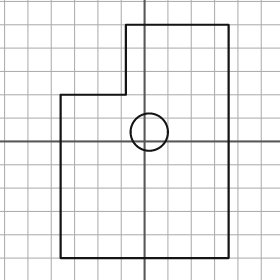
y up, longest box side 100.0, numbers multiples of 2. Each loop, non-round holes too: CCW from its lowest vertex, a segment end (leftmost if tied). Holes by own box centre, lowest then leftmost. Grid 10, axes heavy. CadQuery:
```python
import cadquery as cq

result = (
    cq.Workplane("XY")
    .moveTo(-36.0, -50.0)
    .lineTo(36.0, -50.0)
    .lineTo(36.0, 50.0)
    .lineTo(-8.0, 50.0)
    .lineTo(-8.0, 20.0)
    .lineTo(-36.0, 20.0)
    .close()
    .moveTo(2.0, 4.0)
    .circle(8.0)
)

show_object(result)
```